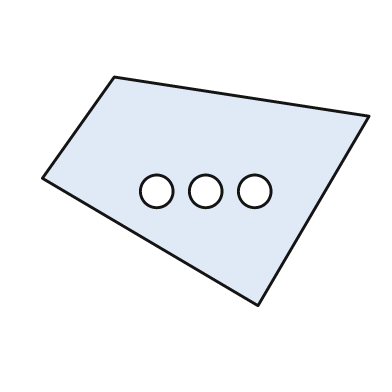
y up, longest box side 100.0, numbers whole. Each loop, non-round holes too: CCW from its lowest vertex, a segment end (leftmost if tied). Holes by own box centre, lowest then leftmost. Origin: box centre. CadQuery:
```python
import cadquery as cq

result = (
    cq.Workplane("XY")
    .moveTo(16.0, -35.0)
    .lineTo(50.0, 23.0)
    .lineTo(-28.0, 35.0)
    .lineTo(-50.0, 4.0)
    .close()
    .moveTo(-15.0, 0.0)
    .circle(5.0)
    .moveTo(0.0, 0.0)
    .circle(5.0)
    .moveTo(15.0, 0.0)
    .circle(5.0)
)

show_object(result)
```